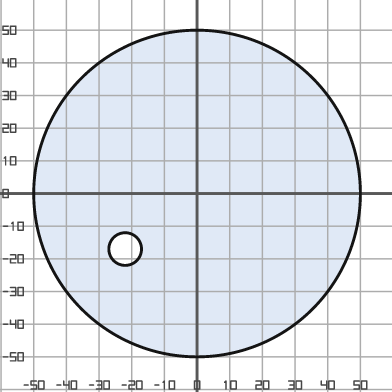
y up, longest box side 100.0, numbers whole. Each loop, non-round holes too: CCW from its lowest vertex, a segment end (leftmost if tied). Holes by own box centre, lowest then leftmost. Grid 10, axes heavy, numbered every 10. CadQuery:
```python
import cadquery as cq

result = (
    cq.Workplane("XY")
    .moveTo(0.0, 0.0)
    .circle(50.0)
    .moveTo(-22.0, -17.0)
    .circle(5.0)
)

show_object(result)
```